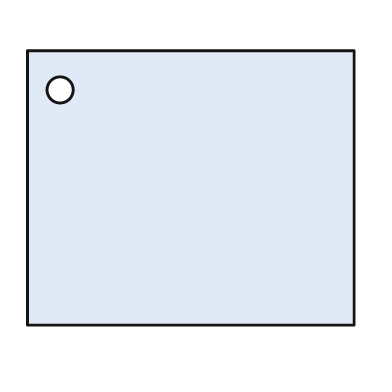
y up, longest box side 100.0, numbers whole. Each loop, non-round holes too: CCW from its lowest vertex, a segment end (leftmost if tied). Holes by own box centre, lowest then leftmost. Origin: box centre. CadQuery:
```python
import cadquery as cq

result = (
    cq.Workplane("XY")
    .moveTo(-50.0, -42.0)
    .lineTo(50.0, -42.0)
    .lineTo(50.0, 42.0)
    .lineTo(-50.0, 42.0)
    .close()
    .moveTo(-40.0, 30.0)
    .circle(4.0)
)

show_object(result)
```